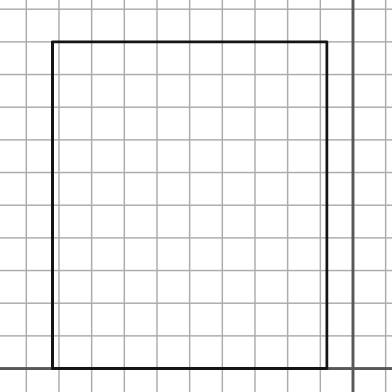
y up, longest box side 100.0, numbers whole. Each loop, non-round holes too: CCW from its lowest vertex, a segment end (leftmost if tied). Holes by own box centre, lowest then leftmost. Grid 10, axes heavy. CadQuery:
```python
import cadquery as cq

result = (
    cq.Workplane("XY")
    .moveTo(-92.0, 0.0)
    .lineTo(-8.0, 0.0)
    .lineTo(-8.0, 100.0)
    .lineTo(-92.0, 100.0)
    .close()
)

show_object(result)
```